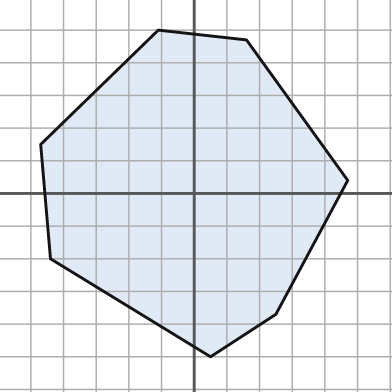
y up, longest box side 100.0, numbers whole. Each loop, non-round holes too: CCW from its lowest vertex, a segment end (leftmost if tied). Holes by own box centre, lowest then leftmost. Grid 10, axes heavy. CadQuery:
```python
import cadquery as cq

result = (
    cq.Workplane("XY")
    .moveTo(5.0, -50.0)
    .lineTo(25.0, -37.0)
    .lineTo(47.0, 4.0)
    .lineTo(16.0, 47.0)
    .lineTo(-11.0, 50.0)
    .lineTo(-47.0, 15.0)
    .lineTo(-44.0, -20.0)
    .close()
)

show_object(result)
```